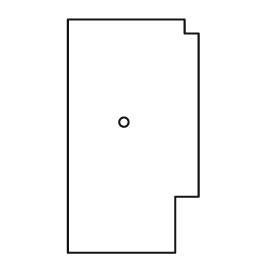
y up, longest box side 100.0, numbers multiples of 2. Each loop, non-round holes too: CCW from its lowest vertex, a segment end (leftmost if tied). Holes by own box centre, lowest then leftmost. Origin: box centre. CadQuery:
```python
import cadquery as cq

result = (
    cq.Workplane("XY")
    .moveTo(-28.0, -50.0)
    .lineTo(18.0, -50.0)
    .lineTo(18.0, -26.0)
    .lineTo(28.0, -26.0)
    .lineTo(28.0, 44.0)
    .lineTo(22.0, 44.0)
    .lineTo(22.0, 50.0)
    .lineTo(-28.0, 50.0)
    .close()
    .moveTo(-4.0, 6.0)
    .circle(2.0)
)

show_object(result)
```